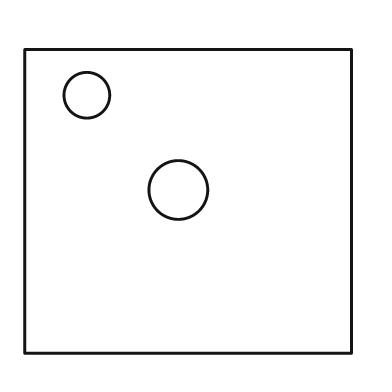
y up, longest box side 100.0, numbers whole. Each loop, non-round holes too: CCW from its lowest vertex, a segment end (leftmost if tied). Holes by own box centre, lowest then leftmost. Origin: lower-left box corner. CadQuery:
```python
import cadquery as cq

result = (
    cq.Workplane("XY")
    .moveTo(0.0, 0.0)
    .lineTo(100.0, 0.0)
    .lineTo(100.0, 93.0)
    .lineTo(0.0, 93.0)
    .close()
    .moveTo(47.0, 50.0)
    .circle(9.0)
    .moveTo(19.0, 79.0)
    .circle(7.0)
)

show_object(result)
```